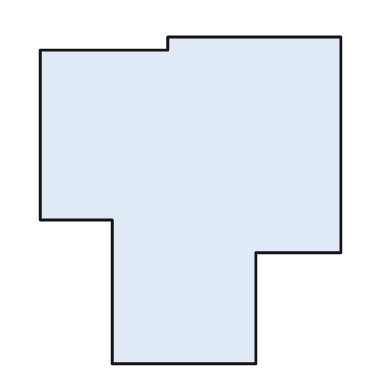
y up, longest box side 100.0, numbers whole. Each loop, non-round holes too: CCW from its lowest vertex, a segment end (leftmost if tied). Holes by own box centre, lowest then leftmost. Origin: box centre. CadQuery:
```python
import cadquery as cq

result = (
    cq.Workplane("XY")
    .moveTo(-24.0, -50.0)
    .lineTo(20.0, -50.0)
    .lineTo(20.0, -16.0)
    .lineTo(46.0, -16.0)
    .lineTo(46.0, 50.0)
    .lineTo(-7.0, 50.0)
    .lineTo(-7.0, 46.0)
    .lineTo(-46.0, 46.0)
    .lineTo(-46.0, -6.0)
    .lineTo(-24.0, -6.0)
    .close()
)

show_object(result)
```